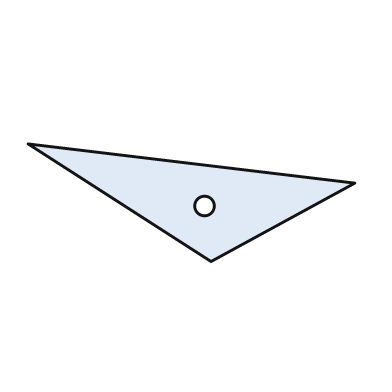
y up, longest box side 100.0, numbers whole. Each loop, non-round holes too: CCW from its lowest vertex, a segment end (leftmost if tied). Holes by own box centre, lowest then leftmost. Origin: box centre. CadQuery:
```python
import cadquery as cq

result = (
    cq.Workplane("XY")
    .moveTo(6.0, -18.0)
    .lineTo(50.0, 6.0)
    .lineTo(-50.0, 18.0)
    .close()
    .moveTo(4.0, -1.0)
    .circle(3.0)
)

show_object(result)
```